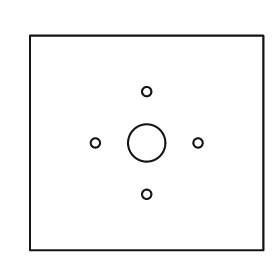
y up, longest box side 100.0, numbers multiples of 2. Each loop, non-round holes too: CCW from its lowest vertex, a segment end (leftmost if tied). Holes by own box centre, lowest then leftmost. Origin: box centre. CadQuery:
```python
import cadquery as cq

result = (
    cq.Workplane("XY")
    .moveTo(-50.0, -46.0)
    .lineTo(50.0, -46.0)
    .lineTo(50.0, 46.0)
    .lineTo(-50.0, 46.0)
    .close()
    .moveTo(0.0, -22.0)
    .circle(2.0)
    .moveTo(-22.0, 0.0)
    .circle(2.0)
    .moveTo(0.0, 0.0)
    .circle(8.0)
    .moveTo(22.0, 0.0)
    .circle(2.0)
    .moveTo(0.0, 22.0)
    .circle(2.0)
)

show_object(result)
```